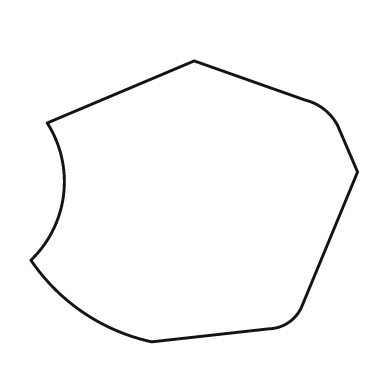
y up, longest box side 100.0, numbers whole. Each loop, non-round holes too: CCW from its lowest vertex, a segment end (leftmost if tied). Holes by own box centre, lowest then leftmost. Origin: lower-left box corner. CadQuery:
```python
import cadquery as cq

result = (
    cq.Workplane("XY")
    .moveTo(37.0, 0.0)
    .lineTo(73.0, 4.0)
    .threePointArc((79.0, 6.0), (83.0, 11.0))
    .lineTo(100.0, 52.0)
    .lineTo(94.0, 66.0)
    .threePointArc((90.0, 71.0), (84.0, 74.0))
    .lineTo(50.0, 86.0)
    .lineTo(5.0, 67.0)
    .threePointArc((10.0, 45.0), (0.0, 25.0))
    .threePointArc((16.0, 9.0), (37.0, 0.0))
    .close()
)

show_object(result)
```